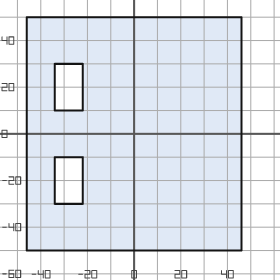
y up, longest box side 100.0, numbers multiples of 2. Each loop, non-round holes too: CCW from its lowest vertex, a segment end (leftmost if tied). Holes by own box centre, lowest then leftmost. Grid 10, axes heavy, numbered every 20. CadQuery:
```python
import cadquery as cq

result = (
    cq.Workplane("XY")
    .moveTo(-46.0, -50.0)
    .lineTo(46.0, -50.0)
    .lineTo(46.0, 50.0)
    .lineTo(-46.0, 50.0)
    .close()
    .moveTo(-34.0, -30.0)
    .lineTo(-22.0, -30.0)
    .lineTo(-22.0, -10.0)
    .lineTo(-34.0, -10.0)
    .close()
    .moveTo(-34.0, 10.0)
    .lineTo(-22.0, 10.0)
    .lineTo(-22.0, 30.0)
    .lineTo(-34.0, 30.0)
    .close()
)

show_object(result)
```